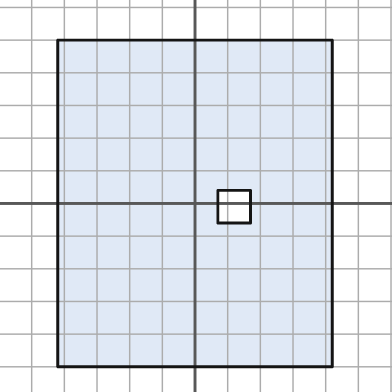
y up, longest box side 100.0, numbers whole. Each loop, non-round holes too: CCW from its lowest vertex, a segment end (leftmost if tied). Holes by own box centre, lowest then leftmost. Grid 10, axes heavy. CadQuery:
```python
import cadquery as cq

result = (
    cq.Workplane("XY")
    .moveTo(-42.0, -50.0)
    .lineTo(42.0, -50.0)
    .lineTo(42.0, 50.0)
    .lineTo(-42.0, 50.0)
    .close()
    .moveTo(7.0, -6.0)
    .lineTo(17.0, -6.0)
    .lineTo(17.0, 4.0)
    .lineTo(7.0, 4.0)
    .close()
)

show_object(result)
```